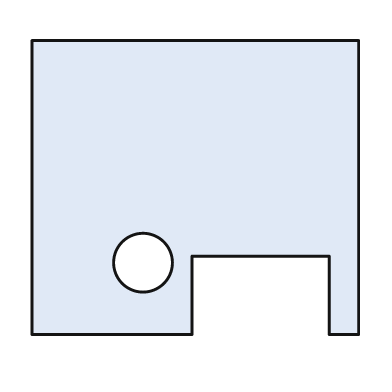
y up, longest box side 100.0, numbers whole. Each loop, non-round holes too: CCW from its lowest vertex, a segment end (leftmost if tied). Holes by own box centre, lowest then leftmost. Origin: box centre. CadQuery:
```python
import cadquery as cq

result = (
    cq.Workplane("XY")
    .moveTo(-50.0, -45.0)
    .lineTo(-1.0, -45.0)
    .lineTo(-1.0, -21.0)
    .lineTo(41.0, -21.0)
    .lineTo(41.0, -45.0)
    .lineTo(50.0, -45.0)
    .lineTo(50.0, 45.0)
    .lineTo(-50.0, 45.0)
    .close()
    .moveTo(-16.0, -23.0)
    .circle(9.0)
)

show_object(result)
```